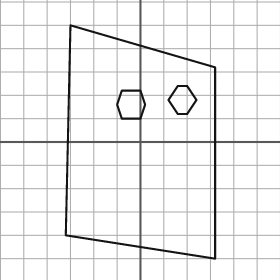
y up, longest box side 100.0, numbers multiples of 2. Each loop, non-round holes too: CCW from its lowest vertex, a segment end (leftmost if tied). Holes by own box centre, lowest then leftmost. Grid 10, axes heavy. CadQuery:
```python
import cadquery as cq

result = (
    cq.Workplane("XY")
    .moveTo(32.0, -50.0)
    .lineTo(32.0, 32.0)
    .lineTo(-30.0, 50.0)
    .lineTo(-32.0, -40.0)
    .close()
    .moveTo(-8.0, 10.0)
    .lineTo(0.0, 10.0)
    .lineTo(2.0, 16.0)
    .lineTo(0.0, 22.0)
    .lineTo(-8.0, 22.0)
    .lineTo(-10.0, 16.0)
    .close()
    .moveTo(16.0, 12.0)
    .lineTo(20.0, 12.0)
    .lineTo(24.0, 18.0)
    .lineTo(20.0, 24.0)
    .lineTo(16.0, 24.0)
    .lineTo(12.0, 18.0)
    .close()
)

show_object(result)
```